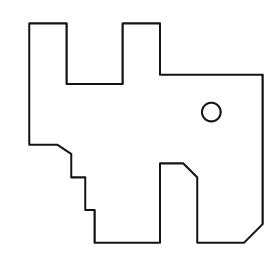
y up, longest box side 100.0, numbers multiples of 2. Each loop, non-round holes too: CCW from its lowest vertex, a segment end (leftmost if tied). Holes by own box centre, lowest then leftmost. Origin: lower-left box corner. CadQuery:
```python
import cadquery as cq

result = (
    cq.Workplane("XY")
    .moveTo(28.0, 0.0)
    .lineTo(56.0, 0.0)
    .lineTo(56.0, 34.0)
    .lineTo(66.0, 34.0)
    .lineTo(72.0, 28.0)
    .lineTo(72.0, 0.0)
    .lineTo(92.0, 0.0)
    .lineTo(100.0, 8.0)
    .lineTo(100.0, 72.0)
    .lineTo(56.0, 72.0)
    .lineTo(56.0, 94.0)
    .lineTo(40.0, 94.0)
    .lineTo(40.0, 68.0)
    .lineTo(16.0, 68.0)
    .lineTo(16.0, 94.0)
    .lineTo(0.0, 94.0)
    .lineTo(0.0, 42.0)
    .lineTo(12.0, 42.0)
    .lineTo(18.0, 38.0)
    .lineTo(18.0, 28.0)
    .lineTo(24.0, 28.0)
    .lineTo(24.0, 14.0)
    .lineTo(28.0, 14.0)
    .close()
    .moveTo(78.0, 56.0)
    .circle(4.0)
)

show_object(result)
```